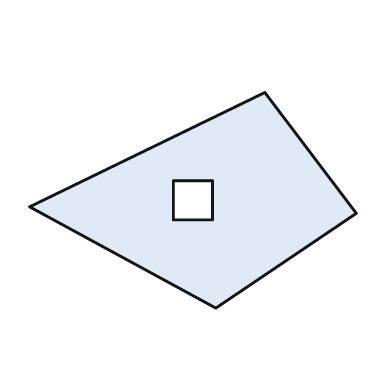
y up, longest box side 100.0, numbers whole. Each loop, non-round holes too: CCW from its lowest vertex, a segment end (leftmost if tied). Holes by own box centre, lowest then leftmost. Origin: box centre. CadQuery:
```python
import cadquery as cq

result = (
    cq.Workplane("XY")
    .moveTo(7.0, -33.0)
    .lineTo(50.0, -4.0)
    .lineTo(22.0, 33.0)
    .lineTo(-50.0, -2.0)
    .close()
    .moveTo(-6.0, -6.0)
    .lineTo(6.0, -6.0)
    .lineTo(6.0, 6.0)
    .lineTo(-6.0, 6.0)
    .close()
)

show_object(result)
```